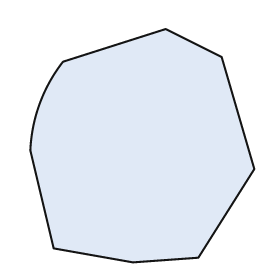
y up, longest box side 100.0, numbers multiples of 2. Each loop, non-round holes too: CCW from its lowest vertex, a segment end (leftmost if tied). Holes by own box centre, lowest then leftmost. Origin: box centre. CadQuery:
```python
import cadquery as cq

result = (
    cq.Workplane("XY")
    .moveTo(-4.0, -50.0)
    .lineTo(24.0, -48.0)
    .lineTo(48.0, -10.0)
    .lineTo(34.0, 38.0)
    .lineTo(10.0, 50.0)
    .lineTo(-34.0, 36.0)
    .threePointArc((-44.0, 18.0), (-48.0, -2.0))
    .lineTo(-38.0, -44.0)
    .close()
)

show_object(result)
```